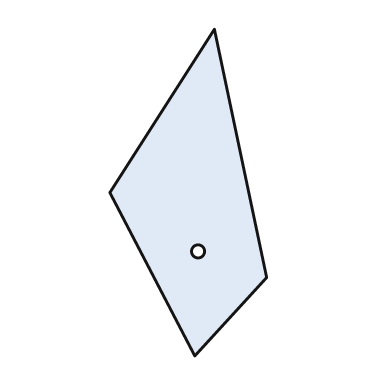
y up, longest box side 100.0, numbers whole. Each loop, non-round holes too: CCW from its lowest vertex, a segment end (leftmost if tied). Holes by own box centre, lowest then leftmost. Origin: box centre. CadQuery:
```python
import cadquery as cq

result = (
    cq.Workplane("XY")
    .moveTo(2.0, -50.0)
    .lineTo(24.0, -26.0)
    .lineTo(8.0, 50.0)
    .lineTo(-24.0, 0.0)
    .close()
    .moveTo(3.0, -18.0)
    .circle(2.0)
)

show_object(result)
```